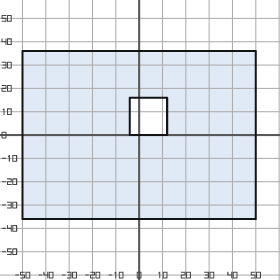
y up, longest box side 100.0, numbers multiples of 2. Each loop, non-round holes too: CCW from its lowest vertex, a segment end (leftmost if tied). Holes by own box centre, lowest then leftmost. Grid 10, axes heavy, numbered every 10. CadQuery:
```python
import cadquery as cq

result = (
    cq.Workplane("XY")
    .moveTo(-50.0, -36.0)
    .lineTo(50.0, -36.0)
    .lineTo(50.0, 36.0)
    .lineTo(-50.0, 36.0)
    .close()
    .moveTo(-4.0, 0.0)
    .lineTo(12.0, 0.0)
    .lineTo(12.0, 16.0)
    .lineTo(-4.0, 16.0)
    .close()
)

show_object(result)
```